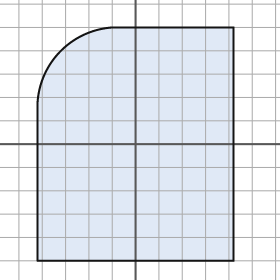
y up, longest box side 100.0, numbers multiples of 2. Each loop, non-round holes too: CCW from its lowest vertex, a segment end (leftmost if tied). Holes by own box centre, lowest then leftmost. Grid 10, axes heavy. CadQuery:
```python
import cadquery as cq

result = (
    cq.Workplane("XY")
    .moveTo(-42.0, -50.0)
    .lineTo(42.0, -50.0)
    .lineTo(42.0, 50.0)
    .lineTo(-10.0, 50.0)
    .threePointArc((-32.0, 40.0), (-42.0, 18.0))
    .close()
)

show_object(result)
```